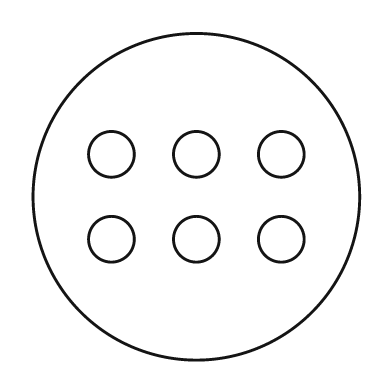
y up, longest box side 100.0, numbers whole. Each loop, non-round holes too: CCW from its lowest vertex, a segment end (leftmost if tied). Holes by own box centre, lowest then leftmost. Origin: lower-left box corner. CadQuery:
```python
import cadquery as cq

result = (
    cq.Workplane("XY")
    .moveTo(50.0, 50.0)
    .circle(50.0)
    .moveTo(24.0, 37.0)
    .circle(7.0)
    .moveTo(50.0, 37.0)
    .circle(7.0)
    .moveTo(76.0, 37.0)
    .circle(7.0)
    .moveTo(24.0, 63.0)
    .circle(7.0)
    .moveTo(50.0, 63.0)
    .circle(7.0)
    .moveTo(76.0, 63.0)
    .circle(7.0)
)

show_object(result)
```